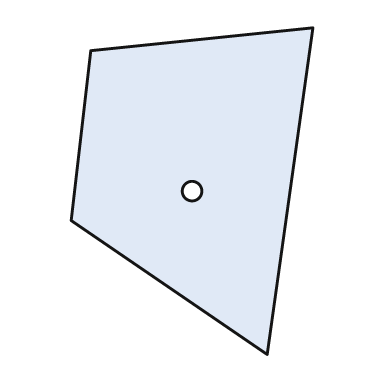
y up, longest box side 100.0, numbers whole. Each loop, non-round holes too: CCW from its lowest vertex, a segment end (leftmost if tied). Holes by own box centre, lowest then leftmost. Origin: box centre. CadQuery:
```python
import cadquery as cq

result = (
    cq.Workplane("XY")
    .moveTo(23.0, -50.0)
    .lineTo(37.0, 50.0)
    .lineTo(-31.0, 43.0)
    .lineTo(-37.0, -9.0)
    .close()
    .moveTo(0.0, 0.0)
    .circle(3.0)
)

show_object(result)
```